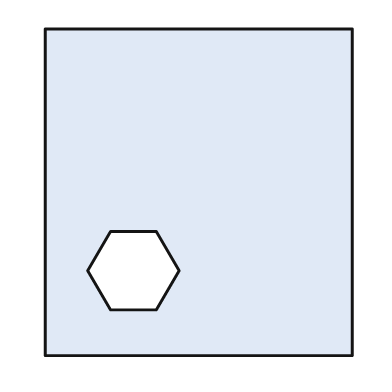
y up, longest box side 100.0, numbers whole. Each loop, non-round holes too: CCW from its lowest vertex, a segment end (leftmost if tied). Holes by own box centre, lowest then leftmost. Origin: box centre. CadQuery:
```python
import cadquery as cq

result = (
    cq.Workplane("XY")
    .moveTo(-47.0, -50.0)
    .lineTo(47.0, -50.0)
    .lineTo(47.0, 50.0)
    .lineTo(-47.0, 50.0)
    .close()
    .moveTo(-27.0, -36.0)
    .lineTo(-13.0, -36.0)
    .lineTo(-6.0, -24.0)
    .lineTo(-13.0, -12.0)
    .lineTo(-27.0, -12.0)
    .lineTo(-34.0, -24.0)
    .close()
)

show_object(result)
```